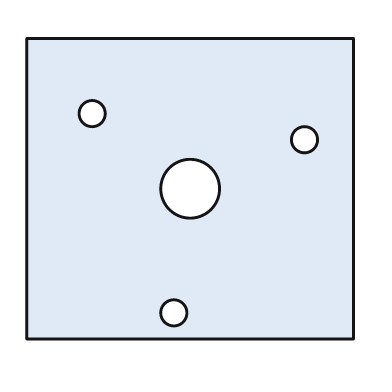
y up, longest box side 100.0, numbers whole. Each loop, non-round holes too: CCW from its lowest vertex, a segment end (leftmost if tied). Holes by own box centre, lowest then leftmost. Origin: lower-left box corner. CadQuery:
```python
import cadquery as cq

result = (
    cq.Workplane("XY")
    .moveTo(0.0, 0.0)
    .lineTo(100.0, 0.0)
    .lineTo(100.0, 92.0)
    .lineTo(0.0, 92.0)
    .close()
    .moveTo(45.0, 8.0)
    .circle(4.0)
    .moveTo(50.0, 46.0)
    .circle(9.0)
    .moveTo(85.0, 61.0)
    .circle(4.0)
    .moveTo(20.0, 69.0)
    .circle(4.0)
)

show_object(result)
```